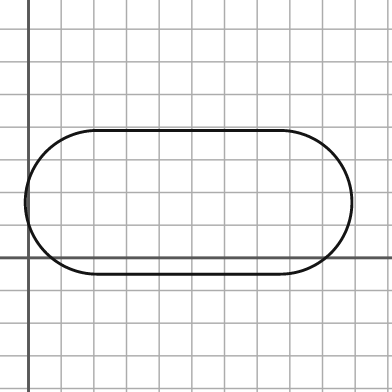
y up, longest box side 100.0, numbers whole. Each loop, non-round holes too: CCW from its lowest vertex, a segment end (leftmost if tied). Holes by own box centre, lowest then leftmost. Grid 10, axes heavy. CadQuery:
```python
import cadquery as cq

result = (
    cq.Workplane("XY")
    .moveTo(21.0, -5.0)
    .lineTo(77.0, -5.0)
    .threePointArc((99.0, 17.0), (77.0, 39.0))
    .lineTo(21.0, 39.0)
    .threePointArc((-1.0, 17.0), (21.0, -5.0))
    .close()
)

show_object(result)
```